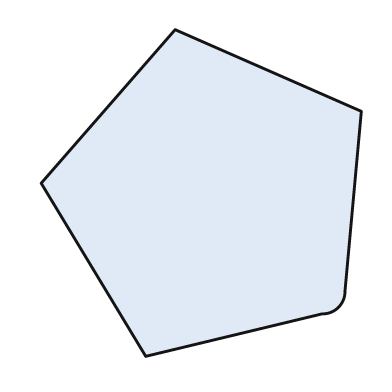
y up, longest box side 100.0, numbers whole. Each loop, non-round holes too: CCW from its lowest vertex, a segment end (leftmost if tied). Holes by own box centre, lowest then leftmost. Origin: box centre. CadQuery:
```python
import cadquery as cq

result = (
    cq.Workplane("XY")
    .moveTo(-17.0, -50.0)
    .lineTo(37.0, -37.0)
    .threePointArc((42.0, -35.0), (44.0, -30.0))
    .lineTo(49.0, 25.0)
    .lineTo(-8.0, 50.0)
    .lineTo(-49.0, 3.0)
    .close()
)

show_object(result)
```